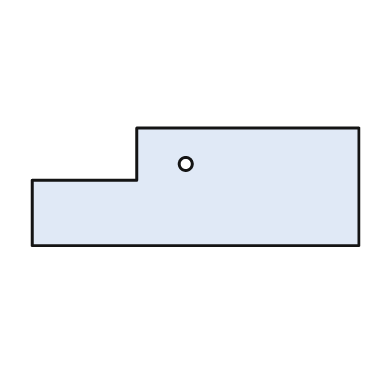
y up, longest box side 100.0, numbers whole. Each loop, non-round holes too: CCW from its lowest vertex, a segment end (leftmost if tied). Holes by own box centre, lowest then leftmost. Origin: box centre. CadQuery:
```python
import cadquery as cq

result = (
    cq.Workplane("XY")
    .moveTo(-50.0, -18.0)
    .lineTo(50.0, -18.0)
    .lineTo(50.0, 18.0)
    .lineTo(-18.0, 18.0)
    .lineTo(-18.0, 2.0)
    .lineTo(-50.0, 2.0)
    .close()
    .moveTo(-3.0, 7.0)
    .circle(2.0)
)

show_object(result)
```